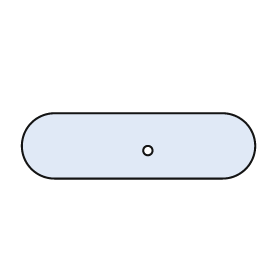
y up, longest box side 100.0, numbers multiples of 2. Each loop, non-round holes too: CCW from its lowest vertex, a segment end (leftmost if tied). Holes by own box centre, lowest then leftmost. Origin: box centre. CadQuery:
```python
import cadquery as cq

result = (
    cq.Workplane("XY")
    .moveTo(-36.0, -14.0)
    .lineTo(36.0, -14.0)
    .threePointArc((50.0, 0.0), (36.0, 14.0))
    .lineTo(-36.0, 14.0)
    .threePointArc((-50.0, 0.0), (-36.0, -14.0))
    .close()
    .moveTo(4.0, -2.0)
    .circle(2.0)
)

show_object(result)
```